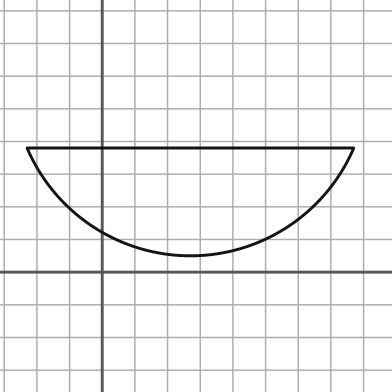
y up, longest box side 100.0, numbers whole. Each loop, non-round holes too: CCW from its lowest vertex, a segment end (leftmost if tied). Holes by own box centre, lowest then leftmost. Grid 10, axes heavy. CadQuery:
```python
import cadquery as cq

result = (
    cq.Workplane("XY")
    .moveTo(-23.0, 38.0)
    .threePointArc((27.0, 5.0), (77.0, 38.0))
    .close()
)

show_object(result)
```